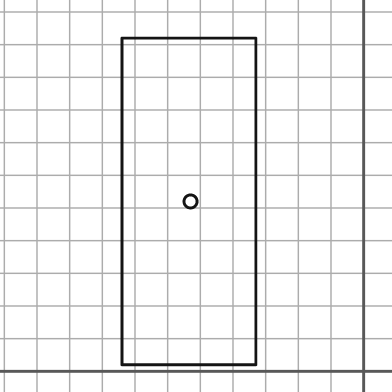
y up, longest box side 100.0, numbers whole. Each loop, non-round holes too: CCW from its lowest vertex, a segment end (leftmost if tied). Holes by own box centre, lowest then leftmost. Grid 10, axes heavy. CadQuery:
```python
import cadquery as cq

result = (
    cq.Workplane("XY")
    .moveTo(-74.0, 2.0)
    .lineTo(-33.0, 2.0)
    .lineTo(-33.0, 102.0)
    .lineTo(-74.0, 102.0)
    .close()
    .moveTo(-53.0, 52.0)
    .circle(2.0)
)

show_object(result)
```